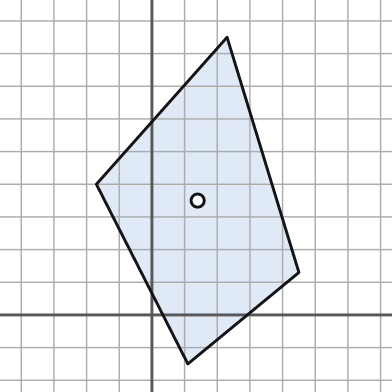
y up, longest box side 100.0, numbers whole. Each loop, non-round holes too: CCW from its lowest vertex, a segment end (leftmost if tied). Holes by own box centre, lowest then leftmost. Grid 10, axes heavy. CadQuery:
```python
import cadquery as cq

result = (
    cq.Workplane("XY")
    .moveTo(11.0, -15.0)
    .lineTo(45.0, 13.0)
    .lineTo(23.0, 85.0)
    .lineTo(-17.0, 40.0)
    .close()
    .moveTo(14.0, 35.0)
    .circle(2.0)
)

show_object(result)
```